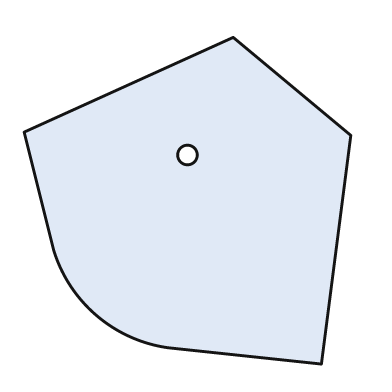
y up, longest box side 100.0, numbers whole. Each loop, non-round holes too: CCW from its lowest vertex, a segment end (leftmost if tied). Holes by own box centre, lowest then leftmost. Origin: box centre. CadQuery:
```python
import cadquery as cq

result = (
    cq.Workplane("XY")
    .moveTo(41.0, -50.0)
    .lineTo(50.0, 20.0)
    .lineTo(14.0, 50.0)
    .lineTo(-50.0, 21.0)
    .lineTo(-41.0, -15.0)
    .threePointArc((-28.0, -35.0), (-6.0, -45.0))
    .close()
    .moveTo(0.0, 14.0)
    .circle(3.0)
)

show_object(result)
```